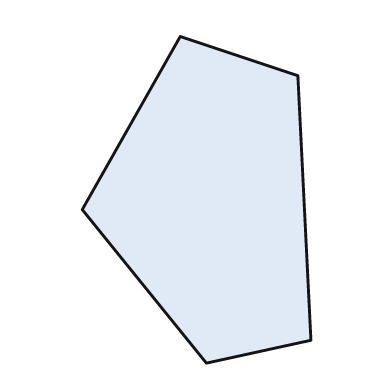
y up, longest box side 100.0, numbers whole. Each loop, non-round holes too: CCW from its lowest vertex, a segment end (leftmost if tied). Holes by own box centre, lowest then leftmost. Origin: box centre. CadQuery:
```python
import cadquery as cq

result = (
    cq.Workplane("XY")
    .moveTo(3.0, -50.0)
    .lineTo(35.0, -43.0)
    .lineTo(31.0, 38.0)
    .lineTo(-5.0, 50.0)
    .lineTo(-35.0, -3.0)
    .close()
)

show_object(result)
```